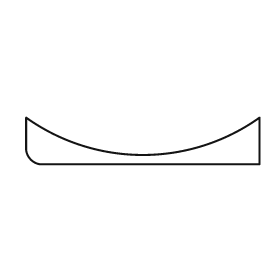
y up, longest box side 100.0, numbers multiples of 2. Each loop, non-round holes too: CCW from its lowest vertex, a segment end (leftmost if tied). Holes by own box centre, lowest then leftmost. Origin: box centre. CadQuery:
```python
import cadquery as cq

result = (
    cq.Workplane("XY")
    .moveTo(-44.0, -10.0)
    .lineTo(50.0, -10.0)
    .lineTo(50.0, 10.0)
    .threePointArc((0.0, -6.0), (-50.0, 10.0))
    .lineTo(-50.0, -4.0)
    .threePointArc((-48.0, -8.0), (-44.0, -10.0))
    .close()
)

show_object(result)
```